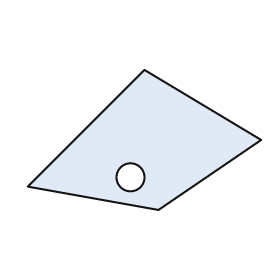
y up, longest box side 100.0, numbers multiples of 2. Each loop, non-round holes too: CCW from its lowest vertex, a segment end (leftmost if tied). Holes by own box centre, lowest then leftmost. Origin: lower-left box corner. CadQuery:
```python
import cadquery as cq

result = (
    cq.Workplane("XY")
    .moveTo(56.0, 0.0)
    .lineTo(100.0, 30.0)
    .lineTo(50.0, 60.0)
    .lineTo(0.0, 10.0)
    .close()
    .moveTo(44.0, 14.0)
    .circle(6.0)
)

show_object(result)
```